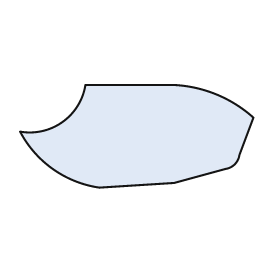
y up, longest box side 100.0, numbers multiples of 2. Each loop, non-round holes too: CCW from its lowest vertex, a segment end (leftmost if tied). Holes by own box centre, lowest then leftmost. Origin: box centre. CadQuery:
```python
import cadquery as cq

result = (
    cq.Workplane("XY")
    .moveTo(-16.0, -22.0)
    .lineTo(16.0, -20.0)
    .lineTo(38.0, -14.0)
    .threePointArc((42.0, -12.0), (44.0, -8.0))
    .lineTo(50.0, 8.0)
    .threePointArc((34.0, 18.0), (16.0, 22.0))
    .lineTo(-22.0, 22.0)
    .threePointArc((-32.0, 6.0), (-50.0, 2.0))
    .threePointArc((-36.0, -14.0), (-16.0, -22.0))
    .close()
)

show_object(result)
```